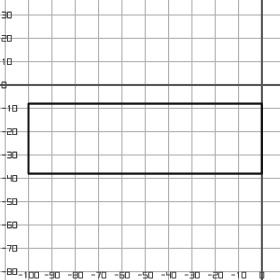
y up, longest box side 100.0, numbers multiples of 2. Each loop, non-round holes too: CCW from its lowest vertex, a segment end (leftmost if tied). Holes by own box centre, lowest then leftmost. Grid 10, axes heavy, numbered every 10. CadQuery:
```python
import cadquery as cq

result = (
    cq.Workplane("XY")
    .moveTo(-100.0, -38.0)
    .lineTo(0.0, -38.0)
    .lineTo(0.0, -8.0)
    .lineTo(-100.0, -8.0)
    .close()
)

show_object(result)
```